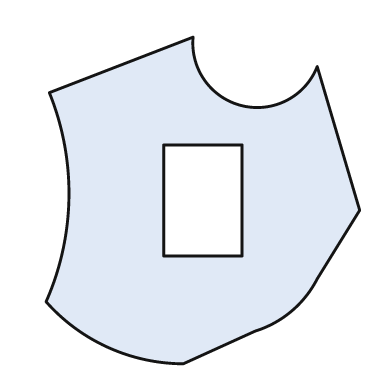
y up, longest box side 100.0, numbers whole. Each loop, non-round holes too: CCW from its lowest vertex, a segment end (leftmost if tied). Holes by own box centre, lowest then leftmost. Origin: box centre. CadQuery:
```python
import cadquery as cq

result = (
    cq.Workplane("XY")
    .moveTo(-6.0, -50.0)
    .lineTo(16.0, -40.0)
    .threePointArc((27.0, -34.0), (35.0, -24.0))
    .lineTo(48.0, -3.0)
    .lineTo(35.0, 41.0)
    .threePointArc((12.0, 29.0), (-3.0, 50.0))
    .lineTo(-47.0, 33.0)
    .threePointArc((-41.0, 1.0), (-48.0, -31.0))
    .threePointArc((-29.0, -45.0), (-6.0, -50.0))
    .close()
    .moveTo(-12.0, -17.0)
    .lineTo(12.0, -17.0)
    .lineTo(12.0, 17.0)
    .lineTo(-12.0, 17.0)
    .close()
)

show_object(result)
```